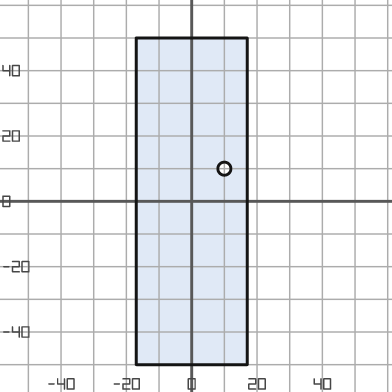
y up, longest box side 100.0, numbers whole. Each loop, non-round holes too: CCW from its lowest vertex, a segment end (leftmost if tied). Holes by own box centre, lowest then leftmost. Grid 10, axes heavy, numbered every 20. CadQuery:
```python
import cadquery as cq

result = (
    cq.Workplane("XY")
    .moveTo(-17.0, -50.0)
    .lineTo(17.0, -50.0)
    .lineTo(17.0, 50.0)
    .lineTo(-17.0, 50.0)
    .close()
    .moveTo(10.0, 10.0)
    .circle(2.0)
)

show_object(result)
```